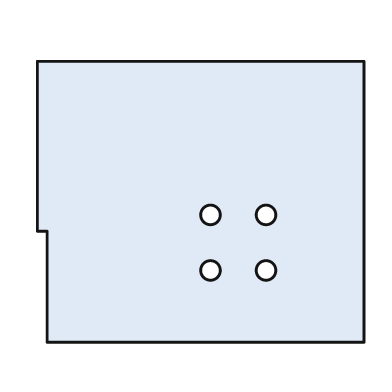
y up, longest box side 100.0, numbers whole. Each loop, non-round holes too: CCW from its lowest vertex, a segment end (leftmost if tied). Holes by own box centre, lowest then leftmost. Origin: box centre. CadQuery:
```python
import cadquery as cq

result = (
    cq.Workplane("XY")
    .moveTo(-47.0, -43.0)
    .lineTo(50.0, -43.0)
    .lineTo(50.0, 43.0)
    .lineTo(-50.0, 43.0)
    .lineTo(-50.0, -9.0)
    .lineTo(-47.0, -9.0)
    .close()
    .moveTo(3.0, -21.0)
    .circle(3.0)
    .moveTo(20.0, -21.0)
    .circle(3.0)
    .moveTo(3.0, -4.0)
    .circle(3.0)
    .moveTo(20.0, -4.0)
    .circle(3.0)
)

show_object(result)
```